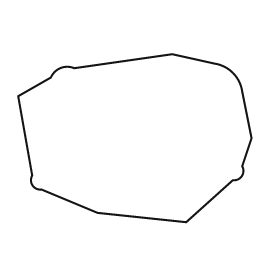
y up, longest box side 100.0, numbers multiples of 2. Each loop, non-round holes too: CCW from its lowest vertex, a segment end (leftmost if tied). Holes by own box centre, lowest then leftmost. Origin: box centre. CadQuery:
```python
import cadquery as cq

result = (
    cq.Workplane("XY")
    .moveTo(22.0, -36.0)
    .lineTo(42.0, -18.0)
    .threePointArc((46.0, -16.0), (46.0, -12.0))
    .lineTo(50.0, 0.0)
    .lineTo(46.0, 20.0)
    .threePointArc((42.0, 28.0), (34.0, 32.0))
    .lineTo(16.0, 36.0)
    .lineTo(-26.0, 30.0)
    .threePointArc((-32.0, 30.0), (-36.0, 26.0))
    .lineTo(-50.0, 18.0)
    .lineTo(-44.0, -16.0)
    .threePointArc((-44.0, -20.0), (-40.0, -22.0))
    .lineTo(-16.0, -32.0)
    .close()
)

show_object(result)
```